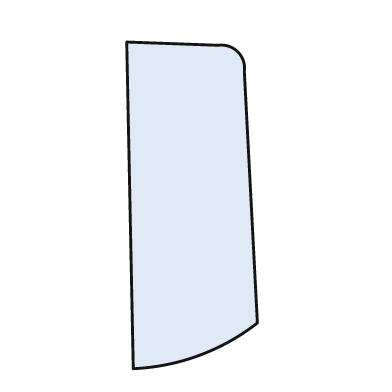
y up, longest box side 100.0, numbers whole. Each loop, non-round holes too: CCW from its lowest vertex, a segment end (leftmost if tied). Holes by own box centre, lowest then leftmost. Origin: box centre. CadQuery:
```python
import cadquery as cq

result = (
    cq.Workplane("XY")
    .moveTo(-18.0, -50.0)
    .threePointArc((2.0, -46.0), (20.0, -36.0))
    .lineTo(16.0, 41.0)
    .threePointArc((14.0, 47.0), (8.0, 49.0))
    .lineTo(-20.0, 50.0)
    .close()
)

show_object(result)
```